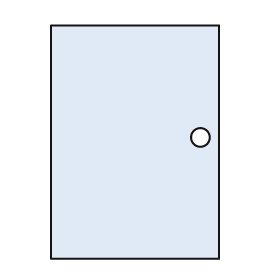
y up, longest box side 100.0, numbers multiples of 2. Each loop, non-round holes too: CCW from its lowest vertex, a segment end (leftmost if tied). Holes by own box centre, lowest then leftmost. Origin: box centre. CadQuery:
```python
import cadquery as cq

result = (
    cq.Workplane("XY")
    .moveTo(-36.0, -50.0)
    .lineTo(36.0, -50.0)
    .lineTo(36.0, 50.0)
    .lineTo(-36.0, 50.0)
    .close()
    .moveTo(28.0, 2.0)
    .circle(4.0)
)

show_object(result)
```